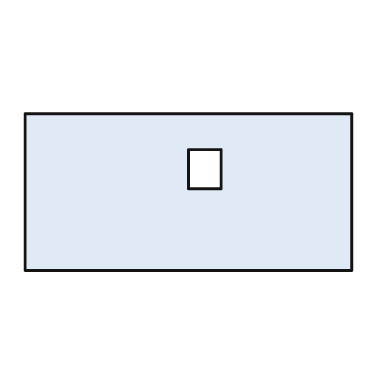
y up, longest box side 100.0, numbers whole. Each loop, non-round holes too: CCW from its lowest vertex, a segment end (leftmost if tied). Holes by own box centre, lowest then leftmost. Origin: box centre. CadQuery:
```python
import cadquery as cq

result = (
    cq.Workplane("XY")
    .moveTo(-50.0, -24.0)
    .lineTo(50.0, -24.0)
    .lineTo(50.0, 24.0)
    .lineTo(-50.0, 24.0)
    .close()
    .moveTo(0.0, 1.0)
    .lineTo(10.0, 1.0)
    .lineTo(10.0, 13.0)
    .lineTo(0.0, 13.0)
    .close()
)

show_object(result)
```